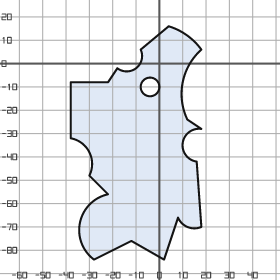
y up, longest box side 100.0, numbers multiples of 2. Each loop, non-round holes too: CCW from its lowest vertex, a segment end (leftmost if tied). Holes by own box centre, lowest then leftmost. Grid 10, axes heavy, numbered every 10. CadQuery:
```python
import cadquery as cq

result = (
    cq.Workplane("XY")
    .moveTo(-28.0, -84.0)
    .lineTo(-12.0, -76.0)
    .lineTo(2.0, -84.0)
    .lineTo(8.0, -66.0)
    .threePointArc((12.0, -70.0), (18.0, -70.0))
    .lineTo(16.0, -42.0)
    .threePointArc((10.0, -34.0), (18.0, -28.0))
    .lineTo(12.0, -24.0)
    .threePointArc((10.0, -8.0), (18.0, 6.0))
    .threePointArc((12.0, 12.0), (4.0, 16.0))
    .lineTo(-8.0, 6.0)
    .threePointArc((-10.0, -2.0), (-18.0, -2.0))
    .lineTo(-22.0, -8.0)
    .lineTo(-38.0, -8.0)
    .lineTo(-38.0, -32.0)
    .threePointArc((-30.0, -38.0), (-30.0, -48.0))
    .lineTo(-22.0, -56.0)
    .threePointArc((-34.0, -68.0), (-28.0, -84.0))
    .close()
    .moveTo(-4.0, -10.0)
    .circle(4.0)
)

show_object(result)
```